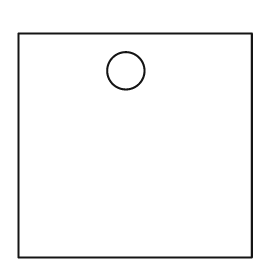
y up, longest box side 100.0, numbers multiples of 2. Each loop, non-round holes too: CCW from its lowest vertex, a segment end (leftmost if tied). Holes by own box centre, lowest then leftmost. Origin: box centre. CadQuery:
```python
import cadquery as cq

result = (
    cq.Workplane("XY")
    .moveTo(-50.0, -48.0)
    .lineTo(50.0, -48.0)
    .lineTo(50.0, 48.0)
    .lineTo(-50.0, 48.0)
    .close()
    .moveTo(-4.0, 32.0)
    .circle(8.0)
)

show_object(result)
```